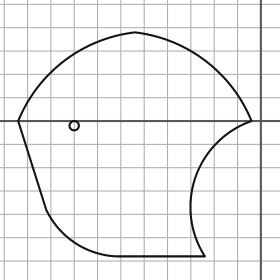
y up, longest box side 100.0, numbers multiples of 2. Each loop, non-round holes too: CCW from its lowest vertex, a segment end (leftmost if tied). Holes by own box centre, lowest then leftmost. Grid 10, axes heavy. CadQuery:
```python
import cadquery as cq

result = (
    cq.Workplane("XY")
    .moveTo(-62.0, -58.0)
    .lineTo(-24.0, -58.0)
    .threePointArc((-28.0, -24.0), (-4.0, 0.0))
    .threePointArc((-24.0, 26.0), (-54.0, 38.0))
    .threePointArc((-84.0, 26.0), (-104.0, 0.0))
    .lineTo(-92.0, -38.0)
    .threePointArc((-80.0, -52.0), (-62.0, -58.0))
    .close()
    .moveTo(-80.0, -2.0)
    .circle(2.0)
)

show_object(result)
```